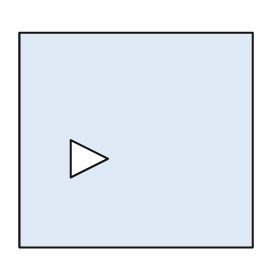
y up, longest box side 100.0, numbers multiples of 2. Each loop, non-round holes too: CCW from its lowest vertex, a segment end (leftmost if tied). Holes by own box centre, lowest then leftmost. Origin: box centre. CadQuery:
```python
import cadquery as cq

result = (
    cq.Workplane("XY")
    .moveTo(-50.0, -46.0)
    .lineTo(50.0, -46.0)
    .lineTo(50.0, 46.0)
    .lineTo(-50.0, 46.0)
    .close()
    .moveTo(-28.0, -16.0)
    .lineTo(-12.0, -8.0)
    .lineTo(-28.0, 0.0)
    .close()
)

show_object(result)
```